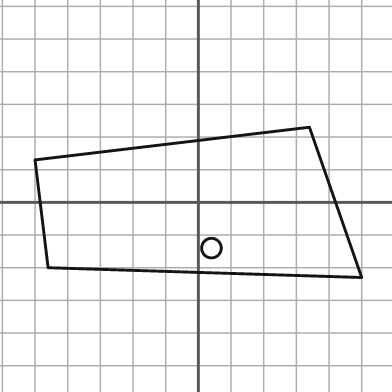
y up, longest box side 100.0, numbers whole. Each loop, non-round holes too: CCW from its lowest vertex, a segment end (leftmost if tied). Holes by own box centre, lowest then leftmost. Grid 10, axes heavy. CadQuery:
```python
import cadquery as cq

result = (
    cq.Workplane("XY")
    .moveTo(50.0, -23.0)
    .lineTo(34.0, 23.0)
    .lineTo(-50.0, 13.0)
    .lineTo(-46.0, -20.0)
    .close()
    .moveTo(4.0, -14.0)
    .circle(3.0)
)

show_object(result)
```